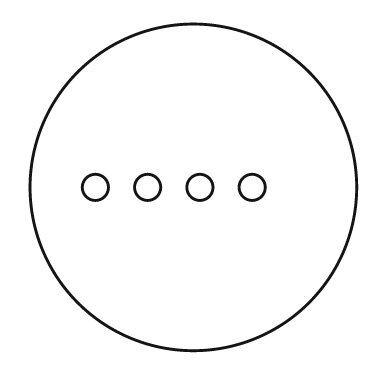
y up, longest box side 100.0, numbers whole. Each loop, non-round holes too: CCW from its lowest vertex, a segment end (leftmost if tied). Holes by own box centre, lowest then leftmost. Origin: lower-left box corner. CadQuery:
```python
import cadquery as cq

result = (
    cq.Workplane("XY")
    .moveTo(50.0, 50.0)
    .circle(50.0)
    .moveTo(20.0, 50.0)
    .circle(4.0)
    .moveTo(36.0, 50.0)
    .circle(4.0)
    .moveTo(52.0, 50.0)
    .circle(4.0)
    .moveTo(68.0, 50.0)
    .circle(4.0)
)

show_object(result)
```